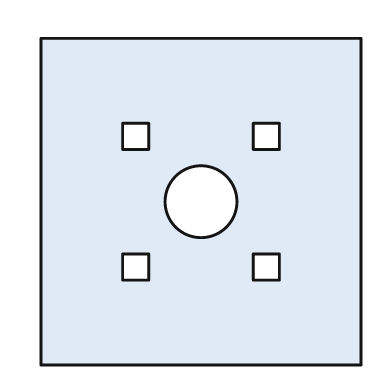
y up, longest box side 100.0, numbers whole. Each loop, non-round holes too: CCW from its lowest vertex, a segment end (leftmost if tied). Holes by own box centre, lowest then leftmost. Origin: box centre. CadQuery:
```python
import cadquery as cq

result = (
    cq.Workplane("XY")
    .moveTo(-49.0, -50.0)
    .lineTo(49.0, -50.0)
    .lineTo(49.0, 50.0)
    .lineTo(-49.0, 50.0)
    .close()
    .moveTo(-24.0, -24.0)
    .lineTo(-16.0, -24.0)
    .lineTo(-16.0, -16.0)
    .lineTo(-24.0, -16.0)
    .close()
    .moveTo(16.0, -24.0)
    .lineTo(24.0, -24.0)
    .lineTo(24.0, -16.0)
    .lineTo(16.0, -16.0)
    .close()
    .moveTo(0.0, 0.0)
    .circle(11.0)
    .moveTo(-24.0, 16.0)
    .lineTo(-16.0, 16.0)
    .lineTo(-16.0, 24.0)
    .lineTo(-24.0, 24.0)
    .close()
    .moveTo(16.0, 16.0)
    .lineTo(24.0, 16.0)
    .lineTo(24.0, 24.0)
    .lineTo(16.0, 24.0)
    .close()
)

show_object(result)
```